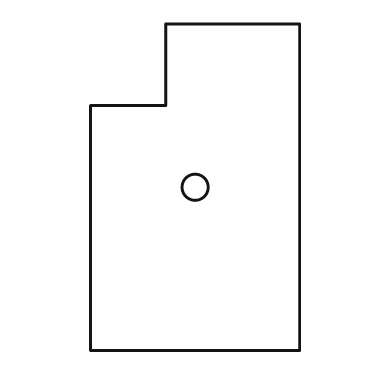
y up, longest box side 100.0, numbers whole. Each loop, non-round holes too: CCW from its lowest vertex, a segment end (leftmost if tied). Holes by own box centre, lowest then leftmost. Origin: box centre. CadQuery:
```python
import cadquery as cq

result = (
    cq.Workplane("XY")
    .moveTo(-32.0, -50.0)
    .lineTo(32.0, -50.0)
    .lineTo(32.0, 50.0)
    .lineTo(-9.0, 50.0)
    .lineTo(-9.0, 25.0)
    .lineTo(-32.0, 25.0)
    .close()
    .moveTo(0.0, 0.0)
    .circle(4.0)
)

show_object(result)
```